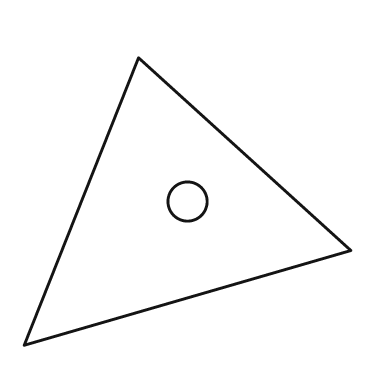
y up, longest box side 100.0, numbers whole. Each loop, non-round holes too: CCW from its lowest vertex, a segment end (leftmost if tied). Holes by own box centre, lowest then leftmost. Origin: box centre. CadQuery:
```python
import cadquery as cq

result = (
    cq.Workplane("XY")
    .moveTo(-50.0, -44.0)
    .lineTo(50.0, -15.0)
    .lineTo(-15.0, 44.0)
    .close()
    .moveTo(0.0, 0.0)
    .circle(6.0)
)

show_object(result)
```